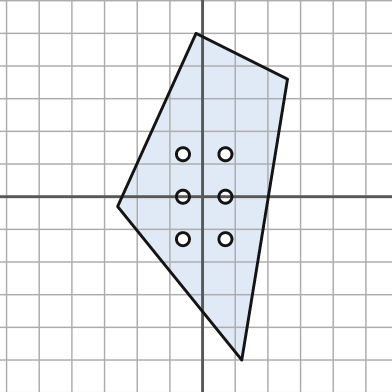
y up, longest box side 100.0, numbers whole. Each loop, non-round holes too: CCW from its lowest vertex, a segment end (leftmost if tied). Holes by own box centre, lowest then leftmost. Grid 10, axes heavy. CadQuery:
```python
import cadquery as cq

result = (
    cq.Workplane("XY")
    .moveTo(12.0, -50.0)
    .lineTo(26.0, 36.0)
    .lineTo(-2.0, 50.0)
    .lineTo(-26.0, -3.0)
    .close()
    .moveTo(-6.0, -13.0)
    .circle(2.0)
    .moveTo(7.0, -13.0)
    .circle(2.0)
    .moveTo(-6.0, 0.0)
    .circle(2.0)
    .moveTo(7.0, 0.0)
    .circle(2.0)
    .moveTo(-6.0, 13.0)
    .circle(2.0)
    .moveTo(7.0, 13.0)
    .circle(2.0)
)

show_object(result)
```